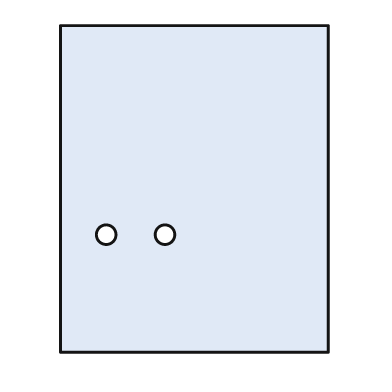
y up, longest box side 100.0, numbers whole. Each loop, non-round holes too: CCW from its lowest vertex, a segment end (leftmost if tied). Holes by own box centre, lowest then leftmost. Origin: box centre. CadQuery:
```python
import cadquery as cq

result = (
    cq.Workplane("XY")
    .moveTo(-41.0, -50.0)
    .lineTo(41.0, -50.0)
    .lineTo(41.0, 50.0)
    .lineTo(-41.0, 50.0)
    .close()
    .moveTo(-27.0, -14.0)
    .circle(3.0)
    .moveTo(-9.0, -14.0)
    .circle(3.0)
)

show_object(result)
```